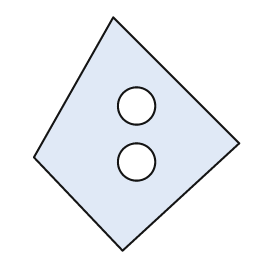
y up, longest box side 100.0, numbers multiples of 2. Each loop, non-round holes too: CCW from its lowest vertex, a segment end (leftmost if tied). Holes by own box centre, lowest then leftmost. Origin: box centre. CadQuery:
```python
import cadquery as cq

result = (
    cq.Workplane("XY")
    .moveTo(-6.0, -50.0)
    .lineTo(44.0, -4.0)
    .lineTo(-10.0, 50.0)
    .lineTo(-44.0, -10.0)
    .close()
    .moveTo(0.0, -12.0)
    .circle(8.0)
    .moveTo(0.0, 12.0)
    .circle(8.0)
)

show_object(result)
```